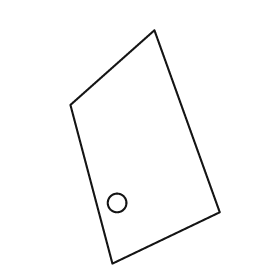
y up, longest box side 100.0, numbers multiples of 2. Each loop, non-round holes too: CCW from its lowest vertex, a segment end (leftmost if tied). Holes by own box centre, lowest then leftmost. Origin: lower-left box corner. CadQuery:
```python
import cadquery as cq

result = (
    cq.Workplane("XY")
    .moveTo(18.0, 0.0)
    .lineTo(64.0, 22.0)
    .lineTo(36.0, 100.0)
    .lineTo(0.0, 68.0)
    .close()
    .moveTo(20.0, 26.0)
    .circle(4.0)
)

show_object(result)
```